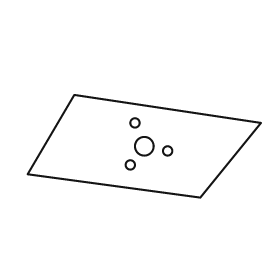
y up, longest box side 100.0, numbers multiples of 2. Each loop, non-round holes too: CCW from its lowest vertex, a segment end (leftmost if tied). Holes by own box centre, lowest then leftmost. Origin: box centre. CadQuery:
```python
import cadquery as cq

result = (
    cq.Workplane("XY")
    .moveTo(24.0, -22.0)
    .lineTo(50.0, 10.0)
    .lineTo(-30.0, 22.0)
    .lineTo(-50.0, -12.0)
    .close()
    .moveTo(-6.0, -8.0)
    .circle(2.0)
    .moveTo(10.0, -2.0)
    .circle(2.0)
    .moveTo(0.0, 0.0)
    .circle(4.0)
    .moveTo(-4.0, 10.0)
    .circle(2.0)
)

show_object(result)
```